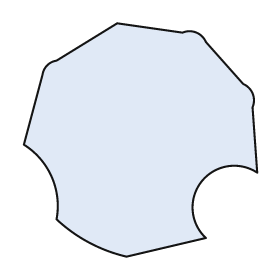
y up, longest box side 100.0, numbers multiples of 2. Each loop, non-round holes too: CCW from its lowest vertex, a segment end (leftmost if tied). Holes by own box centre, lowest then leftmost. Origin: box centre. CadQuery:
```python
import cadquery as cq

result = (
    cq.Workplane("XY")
    .moveTo(-6.0, -50.0)
    .lineTo(28.0, -42.0)
    .threePointArc((26.0, -18.0), (50.0, -14.0))
    .lineTo(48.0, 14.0)
    .threePointArc((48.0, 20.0), (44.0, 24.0))
    .lineTo(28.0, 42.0)
    .threePointArc((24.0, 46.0), (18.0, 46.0))
    .lineTo(-10.0, 50.0)
    .lineTo(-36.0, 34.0)
    .threePointArc((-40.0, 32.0), (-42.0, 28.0))
    .lineTo(-50.0, -2.0)
    .threePointArc((-38.0, -16.0), (-36.0, -34.0))
    .threePointArc((-22.0, -44.0), (-6.0, -50.0))
    .close()
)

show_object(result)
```